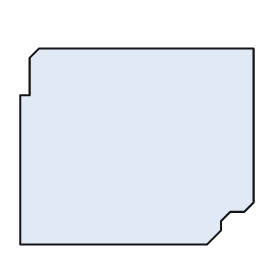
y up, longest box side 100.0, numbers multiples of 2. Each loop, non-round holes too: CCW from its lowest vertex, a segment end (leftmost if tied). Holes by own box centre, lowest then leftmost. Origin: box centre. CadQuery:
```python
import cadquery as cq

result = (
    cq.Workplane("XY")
    .moveTo(-50.0, -42.0)
    .lineTo(30.0, -42.0)
    .lineTo(36.0, -36.0)
    .lineTo(36.0, -32.0)
    .lineTo(40.0, -28.0)
    .lineTo(46.0, -28.0)
    .lineTo(50.0, -24.0)
    .lineTo(50.0, 42.0)
    .lineTo(-42.0, 42.0)
    .lineTo(-46.0, 38.0)
    .lineTo(-46.0, 22.0)
    .lineTo(-50.0, 22.0)
    .close()
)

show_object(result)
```